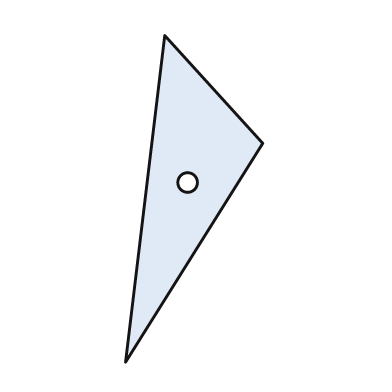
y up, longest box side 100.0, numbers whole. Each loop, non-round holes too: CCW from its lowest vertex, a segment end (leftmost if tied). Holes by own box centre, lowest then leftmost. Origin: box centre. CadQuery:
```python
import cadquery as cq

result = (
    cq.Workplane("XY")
    .moveTo(-21.0, -50.0)
    .lineTo(21.0, 17.0)
    .lineTo(-9.0, 50.0)
    .close()
    .moveTo(-2.0, 5.0)
    .circle(3.0)
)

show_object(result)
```